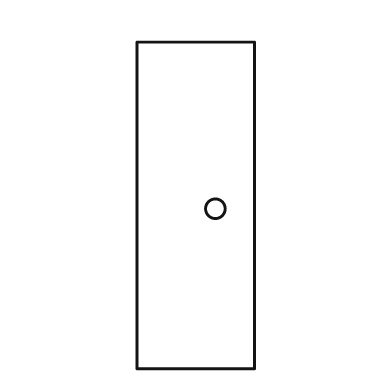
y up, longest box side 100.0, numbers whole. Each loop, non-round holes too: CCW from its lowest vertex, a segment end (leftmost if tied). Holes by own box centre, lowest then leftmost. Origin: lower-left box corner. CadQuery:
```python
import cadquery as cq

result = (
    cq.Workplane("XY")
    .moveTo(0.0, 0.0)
    .lineTo(36.0, 0.0)
    .lineTo(36.0, 100.0)
    .lineTo(0.0, 100.0)
    .close()
    .moveTo(24.0, 49.0)
    .circle(3.0)
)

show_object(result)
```